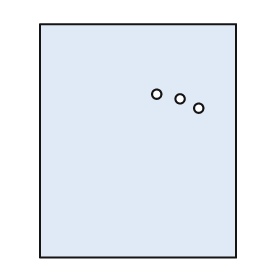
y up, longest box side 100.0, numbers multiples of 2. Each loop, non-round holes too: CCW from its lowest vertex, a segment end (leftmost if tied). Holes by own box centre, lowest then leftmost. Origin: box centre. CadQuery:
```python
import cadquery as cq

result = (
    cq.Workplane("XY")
    .moveTo(-42.0, -50.0)
    .lineTo(42.0, -50.0)
    .lineTo(42.0, 50.0)
    .lineTo(-42.0, 50.0)
    .close()
    .moveTo(26.0, 14.0)
    .circle(2.0)
    .moveTo(18.0, 18.0)
    .circle(2.0)
    .moveTo(8.0, 20.0)
    .circle(2.0)
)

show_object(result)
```